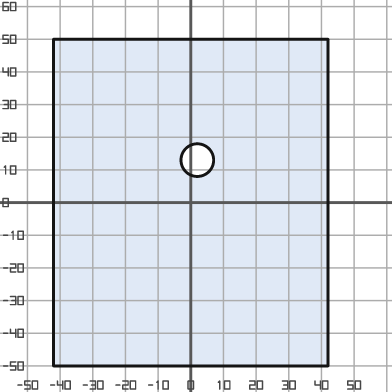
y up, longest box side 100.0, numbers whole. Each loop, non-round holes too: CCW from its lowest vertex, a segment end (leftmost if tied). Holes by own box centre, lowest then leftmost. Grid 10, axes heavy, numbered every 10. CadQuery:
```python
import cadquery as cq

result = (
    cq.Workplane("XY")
    .moveTo(-42.0, -50.0)
    .lineTo(42.0, -50.0)
    .lineTo(42.0, 50.0)
    .lineTo(-42.0, 50.0)
    .close()
    .moveTo(2.0, 13.0)
    .circle(5.0)
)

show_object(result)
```